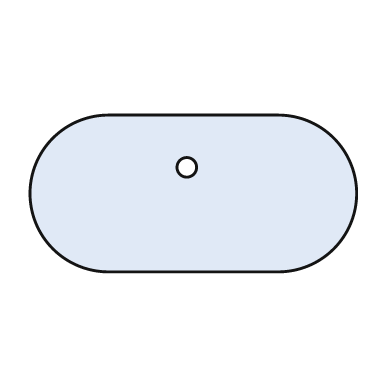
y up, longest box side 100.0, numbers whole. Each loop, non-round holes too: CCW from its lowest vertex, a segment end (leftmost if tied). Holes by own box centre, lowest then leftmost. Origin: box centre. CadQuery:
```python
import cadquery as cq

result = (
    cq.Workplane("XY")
    .moveTo(-26.0, -24.0)
    .lineTo(26.0, -24.0)
    .threePointArc((50.0, 0.0), (26.0, 24.0))
    .lineTo(-26.0, 24.0)
    .threePointArc((-50.0, 0.0), (-26.0, -24.0))
    .close()
    .moveTo(-2.0, 8.0)
    .circle(3.0)
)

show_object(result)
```